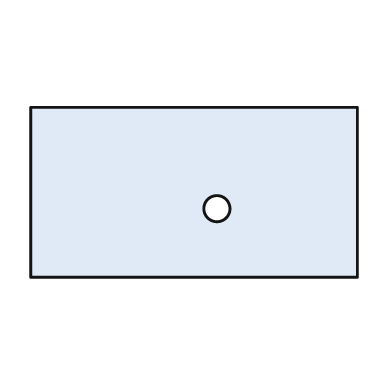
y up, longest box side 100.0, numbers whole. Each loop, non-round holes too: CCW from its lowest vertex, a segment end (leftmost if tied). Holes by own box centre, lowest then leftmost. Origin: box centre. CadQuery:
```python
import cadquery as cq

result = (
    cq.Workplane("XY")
    .moveTo(-50.0, -26.0)
    .lineTo(50.0, -26.0)
    .lineTo(50.0, 26.0)
    .lineTo(-50.0, 26.0)
    .close()
    .moveTo(7.0, -5.0)
    .circle(4.0)
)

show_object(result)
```